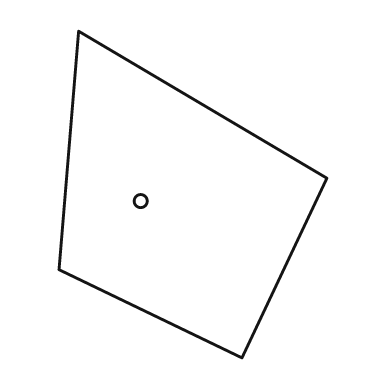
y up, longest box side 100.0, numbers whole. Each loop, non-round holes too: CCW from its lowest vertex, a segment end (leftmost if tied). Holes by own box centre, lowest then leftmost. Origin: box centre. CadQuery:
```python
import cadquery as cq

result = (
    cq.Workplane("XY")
    .moveTo(15.0, -50.0)
    .lineTo(41.0, 5.0)
    .lineTo(-35.0, 50.0)
    .lineTo(-41.0, -23.0)
    .close()
    .moveTo(-16.0, -2.0)
    .circle(2.0)
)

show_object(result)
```